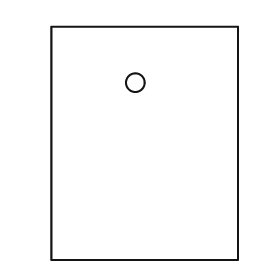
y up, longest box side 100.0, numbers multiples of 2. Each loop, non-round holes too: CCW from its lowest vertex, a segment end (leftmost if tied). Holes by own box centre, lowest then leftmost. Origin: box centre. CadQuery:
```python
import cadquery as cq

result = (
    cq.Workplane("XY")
    .moveTo(-40.0, -50.0)
    .lineTo(40.0, -50.0)
    .lineTo(40.0, 50.0)
    .lineTo(-40.0, 50.0)
    .close()
    .moveTo(-4.0, 26.0)
    .circle(4.0)
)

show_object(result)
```